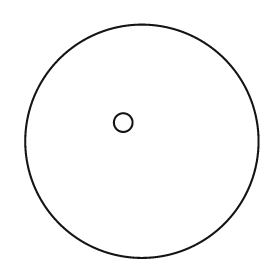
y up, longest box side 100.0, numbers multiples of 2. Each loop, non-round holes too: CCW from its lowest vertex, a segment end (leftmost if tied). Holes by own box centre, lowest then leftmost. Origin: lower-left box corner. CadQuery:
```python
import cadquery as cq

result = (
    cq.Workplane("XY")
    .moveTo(50.0, 50.0)
    .circle(50.0)
    .moveTo(42.0, 58.0)
    .circle(4.0)
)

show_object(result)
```